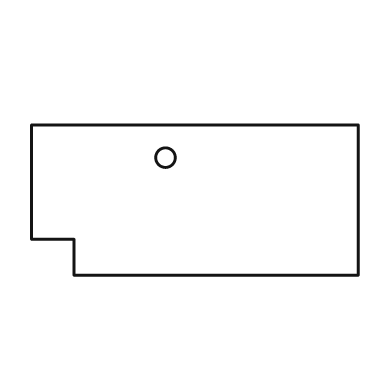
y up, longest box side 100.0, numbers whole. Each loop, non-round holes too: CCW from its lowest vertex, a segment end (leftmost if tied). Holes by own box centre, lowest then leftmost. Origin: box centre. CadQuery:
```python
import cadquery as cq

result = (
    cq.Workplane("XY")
    .moveTo(-37.0, -23.0)
    .lineTo(50.0, -23.0)
    .lineTo(50.0, 23.0)
    .lineTo(-50.0, 23.0)
    .lineTo(-50.0, -12.0)
    .lineTo(-37.0, -12.0)
    .close()
    .moveTo(-9.0, 13.0)
    .circle(3.0)
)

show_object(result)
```